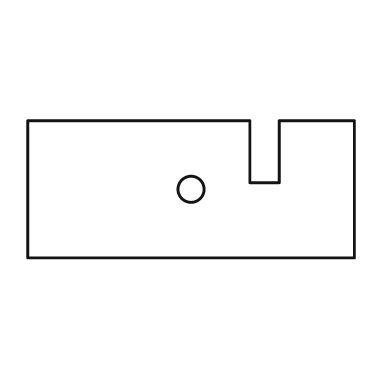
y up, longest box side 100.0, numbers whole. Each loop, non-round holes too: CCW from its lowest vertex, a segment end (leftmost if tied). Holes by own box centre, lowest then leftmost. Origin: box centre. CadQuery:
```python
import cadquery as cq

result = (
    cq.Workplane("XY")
    .moveTo(-50.0, -21.0)
    .lineTo(50.0, -21.0)
    .lineTo(50.0, 21.0)
    .lineTo(27.0, 21.0)
    .lineTo(27.0, 2.0)
    .lineTo(18.0, 2.0)
    .lineTo(18.0, 21.0)
    .lineTo(-50.0, 21.0)
    .close()
    .moveTo(0.0, 0.0)
    .circle(4.0)
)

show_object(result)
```